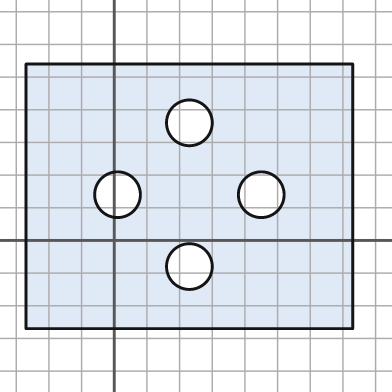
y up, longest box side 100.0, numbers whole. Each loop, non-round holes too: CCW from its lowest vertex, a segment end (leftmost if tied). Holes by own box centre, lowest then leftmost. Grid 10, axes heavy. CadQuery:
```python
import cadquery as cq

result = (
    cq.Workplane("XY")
    .moveTo(-27.0, -27.0)
    .lineTo(73.0, -27.0)
    .lineTo(73.0, 54.0)
    .lineTo(-27.0, 54.0)
    .close()
    .moveTo(23.0, -8.0)
    .circle(7.0)
    .moveTo(1.0, 14.0)
    .circle(7.0)
    .moveTo(45.0, 14.0)
    .circle(7.0)
    .moveTo(23.0, 36.0)
    .circle(7.0)
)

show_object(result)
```